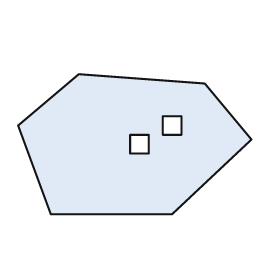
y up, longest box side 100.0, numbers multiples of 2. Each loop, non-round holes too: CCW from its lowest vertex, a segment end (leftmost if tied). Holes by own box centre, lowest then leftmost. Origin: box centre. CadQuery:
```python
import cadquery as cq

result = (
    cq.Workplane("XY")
    .moveTo(-36.0, -30.0)
    .lineTo(16.0, -30.0)
    .lineTo(50.0, 2.0)
    .lineTo(30.0, 26.0)
    .lineTo(-24.0, 30.0)
    .lineTo(-50.0, 8.0)
    .close()
    .moveTo(-2.0, -4.0)
    .lineTo(6.0, -4.0)
    .lineTo(6.0, 4.0)
    .lineTo(-2.0, 4.0)
    .close()
    .moveTo(12.0, 4.0)
    .lineTo(20.0, 4.0)
    .lineTo(20.0, 12.0)
    .lineTo(12.0, 12.0)
    .close()
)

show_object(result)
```